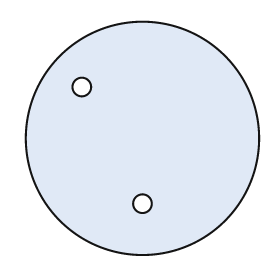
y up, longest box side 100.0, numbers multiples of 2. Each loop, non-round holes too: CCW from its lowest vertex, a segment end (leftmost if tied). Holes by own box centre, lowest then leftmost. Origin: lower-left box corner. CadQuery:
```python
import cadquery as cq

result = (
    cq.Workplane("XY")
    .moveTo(50.0, 50.0)
    .circle(50.0)
    .moveTo(50.0, 22.0)
    .circle(4.0)
    .moveTo(24.0, 72.0)
    .circle(4.0)
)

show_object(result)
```